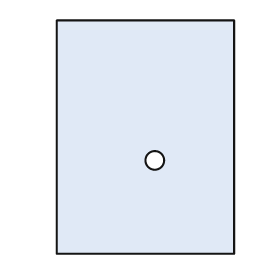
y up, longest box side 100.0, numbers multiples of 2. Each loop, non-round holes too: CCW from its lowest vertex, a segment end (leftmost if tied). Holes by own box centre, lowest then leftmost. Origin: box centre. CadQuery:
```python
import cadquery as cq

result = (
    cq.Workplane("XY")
    .moveTo(-38.0, -50.0)
    .lineTo(38.0, -50.0)
    .lineTo(38.0, 50.0)
    .lineTo(-38.0, 50.0)
    .close()
    .moveTo(4.0, -10.0)
    .circle(4.0)
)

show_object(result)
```